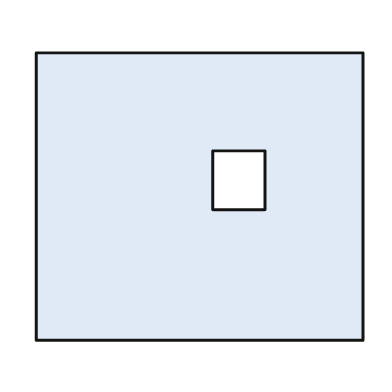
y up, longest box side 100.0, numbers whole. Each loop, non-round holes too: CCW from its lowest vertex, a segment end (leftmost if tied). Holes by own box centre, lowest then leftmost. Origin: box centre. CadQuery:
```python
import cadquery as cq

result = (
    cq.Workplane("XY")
    .moveTo(-50.0, -44.0)
    .lineTo(50.0, -44.0)
    .lineTo(50.0, 44.0)
    .lineTo(-50.0, 44.0)
    .close()
    .moveTo(4.0, -4.0)
    .lineTo(20.0, -4.0)
    .lineTo(20.0, 14.0)
    .lineTo(4.0, 14.0)
    .close()
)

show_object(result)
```